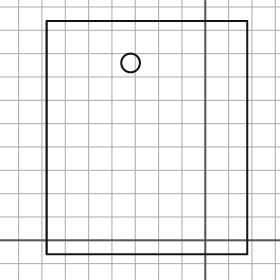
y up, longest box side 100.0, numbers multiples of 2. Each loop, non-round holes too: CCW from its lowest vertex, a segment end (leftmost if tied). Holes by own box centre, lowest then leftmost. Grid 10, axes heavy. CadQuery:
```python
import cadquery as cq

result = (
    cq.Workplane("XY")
    .moveTo(-68.0, -6.0)
    .lineTo(18.0, -6.0)
    .lineTo(18.0, 94.0)
    .lineTo(-68.0, 94.0)
    .close()
    .moveTo(-32.0, 76.0)
    .circle(4.0)
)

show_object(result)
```